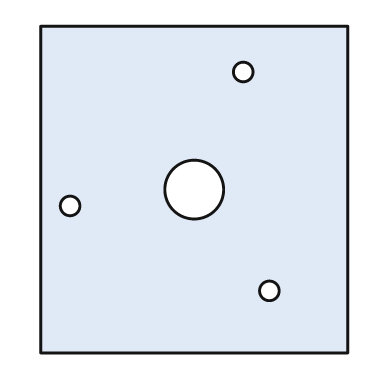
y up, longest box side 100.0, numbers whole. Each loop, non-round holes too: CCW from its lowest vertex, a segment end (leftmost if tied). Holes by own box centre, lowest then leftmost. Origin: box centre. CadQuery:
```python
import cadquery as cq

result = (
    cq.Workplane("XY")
    .moveTo(-47.0, -50.0)
    .lineTo(47.0, -50.0)
    .lineTo(47.0, 50.0)
    .lineTo(-47.0, 50.0)
    .close()
    .moveTo(23.0, -31.0)
    .circle(3.0)
    .moveTo(-38.0, -5.0)
    .circle(3.0)
    .moveTo(0.0, 0.0)
    .circle(9.0)
    .moveTo(15.0, 36.0)
    .circle(3.0)
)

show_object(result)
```